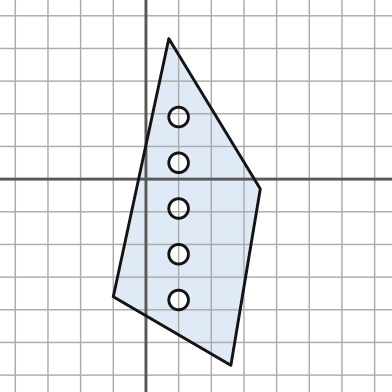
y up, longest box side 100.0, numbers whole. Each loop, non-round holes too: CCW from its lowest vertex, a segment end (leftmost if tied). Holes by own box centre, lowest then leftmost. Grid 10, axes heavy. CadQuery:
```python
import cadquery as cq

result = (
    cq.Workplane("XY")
    .moveTo(26.0, -57.0)
    .lineTo(35.0, -3.0)
    .lineTo(7.0, 43.0)
    .lineTo(-10.0, -36.0)
    .close()
    .moveTo(10.0, -37.0)
    .circle(3.0)
    .moveTo(10.0, -23.0)
    .circle(3.0)
    .moveTo(10.0, -9.0)
    .circle(3.0)
    .moveTo(10.0, 5.0)
    .circle(3.0)
    .moveTo(10.0, 19.0)
    .circle(3.0)
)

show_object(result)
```